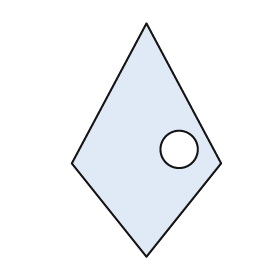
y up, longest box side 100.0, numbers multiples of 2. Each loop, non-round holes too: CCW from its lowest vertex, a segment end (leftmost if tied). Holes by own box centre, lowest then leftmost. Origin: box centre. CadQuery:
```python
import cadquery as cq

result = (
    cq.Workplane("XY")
    .moveTo(0.0, -50.0)
    .lineTo(32.0, -10.0)
    .lineTo(0.0, 50.0)
    .lineTo(-32.0, -10.0)
    .close()
    .moveTo(14.0, -4.0)
    .circle(8.0)
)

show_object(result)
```